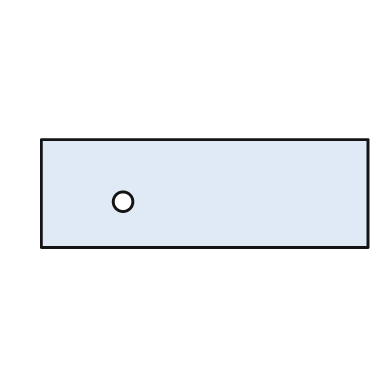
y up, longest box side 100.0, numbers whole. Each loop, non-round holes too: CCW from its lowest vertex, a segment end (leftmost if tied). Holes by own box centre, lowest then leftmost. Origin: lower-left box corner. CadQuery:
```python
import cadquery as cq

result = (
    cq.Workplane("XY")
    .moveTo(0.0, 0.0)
    .lineTo(100.0, 0.0)
    .lineTo(100.0, 33.0)
    .lineTo(0.0, 33.0)
    .close()
    .moveTo(25.0, 14.0)
    .circle(3.0)
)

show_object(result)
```